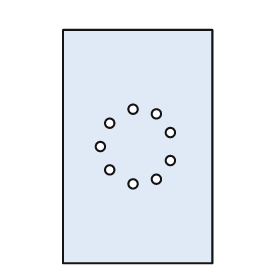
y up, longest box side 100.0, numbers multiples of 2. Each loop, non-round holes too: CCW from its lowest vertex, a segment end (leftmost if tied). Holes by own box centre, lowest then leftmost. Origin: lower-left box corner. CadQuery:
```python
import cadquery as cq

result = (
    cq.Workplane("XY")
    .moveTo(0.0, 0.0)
    .lineTo(64.0, 0.0)
    .lineTo(64.0, 100.0)
    .lineTo(0.0, 100.0)
    .close()
    .moveTo(30.0, 34.0)
    .circle(2.0)
    .moveTo(40.0, 36.0)
    .circle(2.0)
    .moveTo(20.0, 40.0)
    .circle(2.0)
    .moveTo(46.0, 44.0)
    .circle(2.0)
    .moveTo(16.0, 50.0)
    .circle(2.0)
    .moveTo(46.0, 56.0)
    .circle(2.0)
    .moveTo(20.0, 60.0)
    .circle(2.0)
    .moveTo(40.0, 64.0)
    .circle(2.0)
    .moveTo(30.0, 66.0)
    .circle(2.0)
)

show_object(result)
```